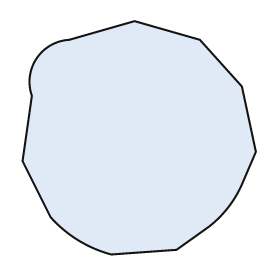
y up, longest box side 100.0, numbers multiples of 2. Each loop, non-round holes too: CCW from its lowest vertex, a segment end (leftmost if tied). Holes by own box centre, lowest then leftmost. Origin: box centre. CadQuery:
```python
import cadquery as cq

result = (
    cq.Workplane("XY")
    .moveTo(-12.0, -50.0)
    .lineTo(16.0, -48.0)
    .lineTo(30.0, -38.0)
    .threePointArc((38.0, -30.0), (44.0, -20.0))
    .lineTo(50.0, -6.0)
    .lineTo(44.0, 22.0)
    .lineTo(26.0, 42.0)
    .lineTo(-2.0, 50.0)
    .lineTo(-30.0, 42.0)
    .threePointArc((-44.0, 34.0), (-46.0, 18.0))
    .lineTo(-50.0, -10.0)
    .lineTo(-38.0, -34.0)
    .threePointArc((-26.0, -44.0), (-12.0, -50.0))
    .close()
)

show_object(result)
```